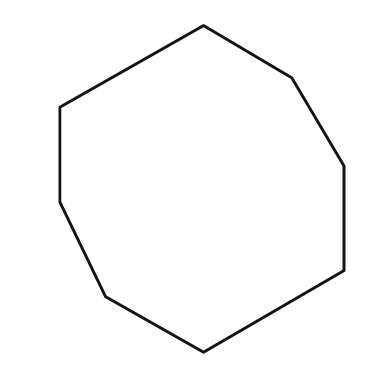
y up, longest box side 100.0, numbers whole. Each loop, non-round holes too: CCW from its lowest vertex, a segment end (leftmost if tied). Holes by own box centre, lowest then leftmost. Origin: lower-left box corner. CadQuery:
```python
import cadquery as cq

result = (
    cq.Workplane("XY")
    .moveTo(44.0, 0.0)
    .lineTo(87.0, 25.0)
    .lineTo(87.0, 57.0)
    .lineTo(71.0, 84.0)
    .lineTo(44.0, 100.0)
    .lineTo(0.0, 75.0)
    .lineTo(0.0, 46.0)
    .lineTo(14.0, 17.0)
    .close()
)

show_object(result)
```